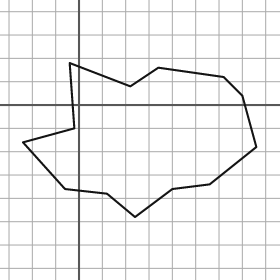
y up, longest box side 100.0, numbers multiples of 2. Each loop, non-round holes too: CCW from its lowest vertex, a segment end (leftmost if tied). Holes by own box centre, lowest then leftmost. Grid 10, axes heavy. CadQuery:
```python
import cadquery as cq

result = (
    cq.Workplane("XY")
    .moveTo(24.0, -48.0)
    .lineTo(40.0, -36.0)
    .lineTo(56.0, -34.0)
    .lineTo(76.0, -18.0)
    .lineTo(70.0, 4.0)
    .lineTo(62.0, 12.0)
    .lineTo(34.0, 16.0)
    .lineTo(22.0, 8.0)
    .lineTo(-4.0, 18.0)
    .lineTo(-2.0, -10.0)
    .lineTo(-24.0, -16.0)
    .lineTo(-6.0, -36.0)
    .lineTo(12.0, -38.0)
    .close()
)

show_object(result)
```